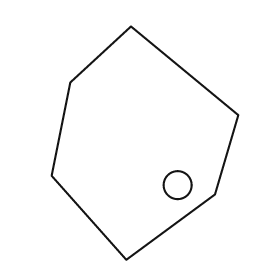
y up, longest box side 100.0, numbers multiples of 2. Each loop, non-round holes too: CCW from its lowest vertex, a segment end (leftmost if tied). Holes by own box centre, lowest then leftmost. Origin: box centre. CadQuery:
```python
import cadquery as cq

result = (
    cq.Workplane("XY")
    .moveTo(-8.0, -50.0)
    .lineTo(30.0, -22.0)
    .lineTo(40.0, 12.0)
    .lineTo(-6.0, 50.0)
    .lineTo(-32.0, 26.0)
    .lineTo(-40.0, -14.0)
    .close()
    .moveTo(14.0, -18.0)
    .circle(6.0)
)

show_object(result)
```